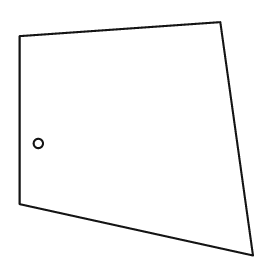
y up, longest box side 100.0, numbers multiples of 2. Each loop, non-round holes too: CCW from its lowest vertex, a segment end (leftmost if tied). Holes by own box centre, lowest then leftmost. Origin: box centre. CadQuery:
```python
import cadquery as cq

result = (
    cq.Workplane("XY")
    .moveTo(50.0, -50.0)
    .lineTo(36.0, 50.0)
    .lineTo(-50.0, 44.0)
    .lineTo(-50.0, -28.0)
    .close()
    .moveTo(-42.0, -2.0)
    .circle(2.0)
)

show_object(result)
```